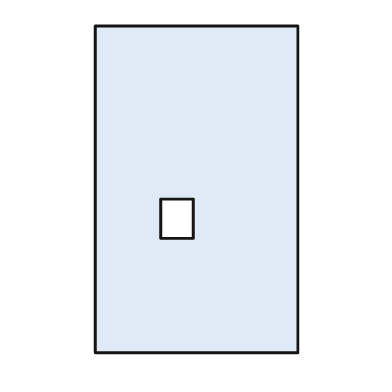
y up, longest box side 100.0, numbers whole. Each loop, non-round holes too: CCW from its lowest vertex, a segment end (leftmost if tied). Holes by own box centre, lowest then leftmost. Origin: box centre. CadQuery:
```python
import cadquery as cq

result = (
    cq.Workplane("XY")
    .moveTo(-31.0, -50.0)
    .lineTo(31.0, -50.0)
    .lineTo(31.0, 50.0)
    .lineTo(-31.0, 50.0)
    .close()
    .moveTo(-11.0, -15.0)
    .lineTo(-1.0, -15.0)
    .lineTo(-1.0, -3.0)
    .lineTo(-11.0, -3.0)
    .close()
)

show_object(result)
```